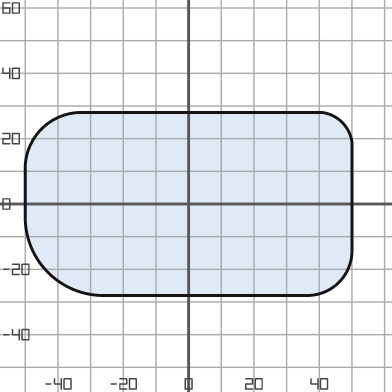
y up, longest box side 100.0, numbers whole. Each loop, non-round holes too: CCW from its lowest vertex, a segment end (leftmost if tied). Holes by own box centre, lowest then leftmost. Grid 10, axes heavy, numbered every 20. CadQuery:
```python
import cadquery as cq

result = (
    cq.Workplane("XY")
    .moveTo(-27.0, -28.0)
    .lineTo(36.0, -28.0)
    .threePointArc((46.0, -24.0), (50.0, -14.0))
    .lineTo(50.0, 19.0)
    .threePointArc((47.0, 25.0), (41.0, 28.0))
    .lineTo(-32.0, 28.0)
    .threePointArc((-45.0, 23.0), (-50.0, 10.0))
    .lineTo(-50.0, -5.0)
    .threePointArc((-43.0, -21.0), (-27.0, -28.0))
    .close()
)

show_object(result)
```